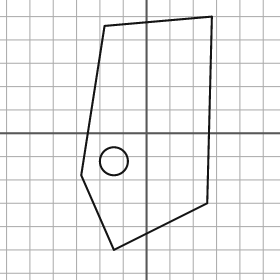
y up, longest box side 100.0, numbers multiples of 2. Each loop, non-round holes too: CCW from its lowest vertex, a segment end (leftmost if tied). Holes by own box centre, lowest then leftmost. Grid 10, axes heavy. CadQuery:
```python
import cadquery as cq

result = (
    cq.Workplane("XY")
    .moveTo(-14.0, -50.0)
    .lineTo(26.0, -30.0)
    .lineTo(28.0, 50.0)
    .lineTo(-18.0, 46.0)
    .lineTo(-28.0, -18.0)
    .close()
    .moveTo(-14.0, -12.0)
    .circle(6.0)
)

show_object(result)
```